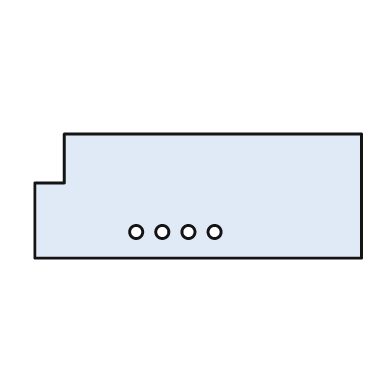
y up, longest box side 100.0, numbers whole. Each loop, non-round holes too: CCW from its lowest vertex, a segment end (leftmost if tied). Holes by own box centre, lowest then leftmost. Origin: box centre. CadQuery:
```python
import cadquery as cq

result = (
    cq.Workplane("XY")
    .moveTo(-50.0, -19.0)
    .lineTo(50.0, -19.0)
    .lineTo(50.0, 19.0)
    .lineTo(-41.0, 19.0)
    .lineTo(-41.0, 4.0)
    .lineTo(-50.0, 4.0)
    .close()
    .moveTo(-19.0, -11.0)
    .circle(2.0)
    .moveTo(-11.0, -11.0)
    .circle(2.0)
    .moveTo(-3.0, -11.0)
    .circle(2.0)
    .moveTo(5.0, -11.0)
    .circle(2.0)
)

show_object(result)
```